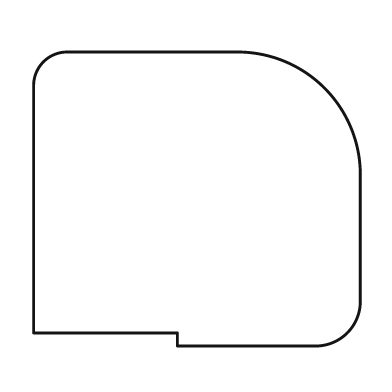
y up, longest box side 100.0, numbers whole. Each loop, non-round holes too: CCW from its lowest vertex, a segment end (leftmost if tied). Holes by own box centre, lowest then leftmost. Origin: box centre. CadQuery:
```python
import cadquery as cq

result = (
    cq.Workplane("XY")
    .moveTo(-6.0, -45.0)
    .lineTo(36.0, -45.0)
    .threePointArc((46.0, -41.0), (50.0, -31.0))
    .lineTo(50.0, 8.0)
    .threePointArc((39.0, 34.0), (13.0, 45.0))
    .lineTo(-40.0, 45.0)
    .threePointArc((-47.0, 42.0), (-50.0, 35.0))
    .lineTo(-50.0, -41.0)
    .lineTo(-6.0, -41.0)
    .close()
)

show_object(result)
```